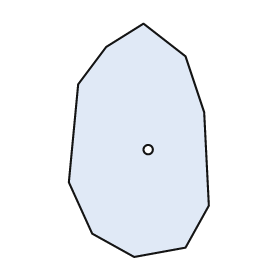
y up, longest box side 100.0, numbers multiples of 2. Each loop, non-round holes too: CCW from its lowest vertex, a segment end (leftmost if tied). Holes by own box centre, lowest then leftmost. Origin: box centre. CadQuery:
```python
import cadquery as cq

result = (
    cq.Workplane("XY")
    .moveTo(-2.0, -50.0)
    .lineTo(20.0, -46.0)
    .lineTo(30.0, -28.0)
    .lineTo(28.0, 12.0)
    .lineTo(20.0, 36.0)
    .lineTo(2.0, 50.0)
    .lineTo(-14.0, 40.0)
    .lineTo(-26.0, 24.0)
    .lineTo(-30.0, -18.0)
    .lineTo(-20.0, -40.0)
    .close()
    .moveTo(4.0, -4.0)
    .circle(2.0)
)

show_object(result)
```